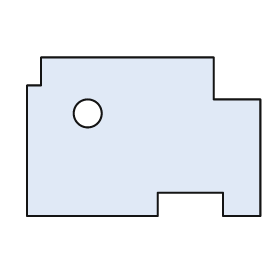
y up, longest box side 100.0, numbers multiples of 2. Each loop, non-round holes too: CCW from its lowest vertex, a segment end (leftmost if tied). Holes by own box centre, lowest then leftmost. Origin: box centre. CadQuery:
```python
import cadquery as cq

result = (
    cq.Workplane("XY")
    .moveTo(-50.0, -34.0)
    .lineTo(6.0, -34.0)
    .lineTo(6.0, -24.0)
    .lineTo(34.0, -24.0)
    .lineTo(34.0, -34.0)
    .lineTo(50.0, -34.0)
    .lineTo(50.0, 16.0)
    .lineTo(30.0, 16.0)
    .lineTo(30.0, 34.0)
    .lineTo(-44.0, 34.0)
    .lineTo(-44.0, 22.0)
    .lineTo(-50.0, 22.0)
    .close()
    .moveTo(-24.0, 10.0)
    .circle(6.0)
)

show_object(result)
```